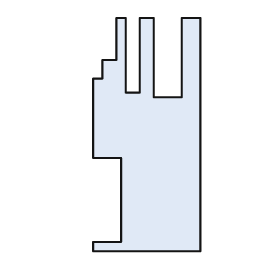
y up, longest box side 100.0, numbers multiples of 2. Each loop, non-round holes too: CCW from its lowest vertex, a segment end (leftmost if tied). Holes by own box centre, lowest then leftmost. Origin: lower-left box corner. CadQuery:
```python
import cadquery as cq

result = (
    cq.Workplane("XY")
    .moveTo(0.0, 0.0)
    .lineTo(46.0, 0.0)
    .lineTo(46.0, 100.0)
    .lineTo(38.0, 100.0)
    .lineTo(38.0, 66.0)
    .lineTo(26.0, 66.0)
    .lineTo(26.0, 100.0)
    .lineTo(20.0, 100.0)
    .lineTo(20.0, 68.0)
    .lineTo(14.0, 68.0)
    .lineTo(14.0, 100.0)
    .lineTo(10.0, 100.0)
    .lineTo(10.0, 82.0)
    .lineTo(4.0, 82.0)
    .lineTo(4.0, 74.0)
    .lineTo(0.0, 74.0)
    .lineTo(0.0, 40.0)
    .lineTo(12.0, 40.0)
    .lineTo(12.0, 4.0)
    .lineTo(0.0, 4.0)
    .close()
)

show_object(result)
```